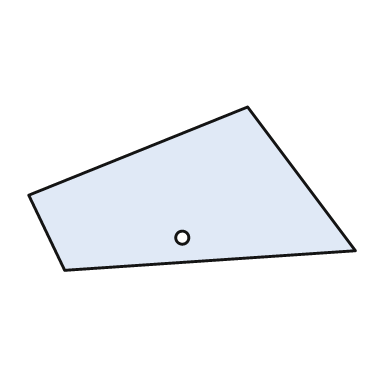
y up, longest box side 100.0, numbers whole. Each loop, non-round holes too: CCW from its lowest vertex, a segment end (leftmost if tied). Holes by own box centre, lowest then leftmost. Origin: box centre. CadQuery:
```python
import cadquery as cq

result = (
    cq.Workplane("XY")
    .moveTo(-39.0, -25.0)
    .lineTo(50.0, -19.0)
    .lineTo(17.0, 25.0)
    .lineTo(-50.0, -2.0)
    .close()
    .moveTo(-3.0, -15.0)
    .circle(2.0)
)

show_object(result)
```